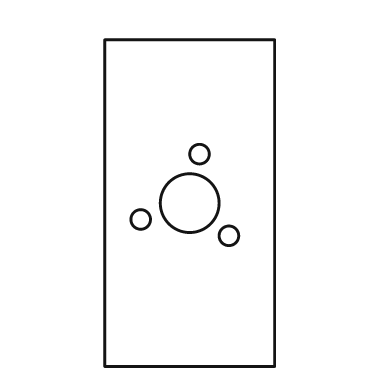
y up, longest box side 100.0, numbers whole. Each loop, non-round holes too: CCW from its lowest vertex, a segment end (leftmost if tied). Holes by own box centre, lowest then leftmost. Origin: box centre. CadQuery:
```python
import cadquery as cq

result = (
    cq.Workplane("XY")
    .moveTo(-26.0, -50.0)
    .lineTo(26.0, -50.0)
    .lineTo(26.0, 50.0)
    .lineTo(-26.0, 50.0)
    .close()
    .moveTo(12.0, -10.0)
    .circle(3.0)
    .moveTo(-15.0, -5.0)
    .circle(3.0)
    .moveTo(0.0, 0.0)
    .circle(9.0)
    .moveTo(3.0, 15.0)
    .circle(3.0)
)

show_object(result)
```